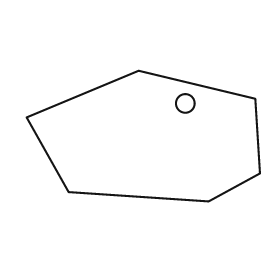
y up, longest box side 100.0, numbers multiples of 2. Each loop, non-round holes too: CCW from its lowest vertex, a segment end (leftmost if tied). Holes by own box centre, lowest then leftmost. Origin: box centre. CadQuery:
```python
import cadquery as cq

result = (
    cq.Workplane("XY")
    .moveTo(28.0, -28.0)
    .lineTo(50.0, -16.0)
    .lineTo(48.0, 16.0)
    .lineTo(-2.0, 28.0)
    .lineTo(-50.0, 8.0)
    .lineTo(-32.0, -24.0)
    .close()
    .moveTo(18.0, 14.0)
    .circle(4.0)
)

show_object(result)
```